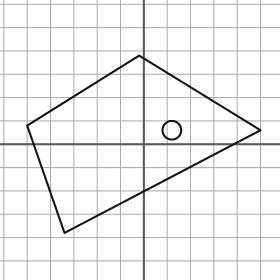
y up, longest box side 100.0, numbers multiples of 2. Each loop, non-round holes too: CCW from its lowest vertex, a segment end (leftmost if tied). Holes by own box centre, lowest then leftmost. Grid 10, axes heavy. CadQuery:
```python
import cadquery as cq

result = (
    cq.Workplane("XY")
    .moveTo(-34.0, -38.0)
    .lineTo(50.0, 6.0)
    .lineTo(-2.0, 38.0)
    .lineTo(-50.0, 8.0)
    .close()
    .moveTo(12.0, 6.0)
    .circle(4.0)
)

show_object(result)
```